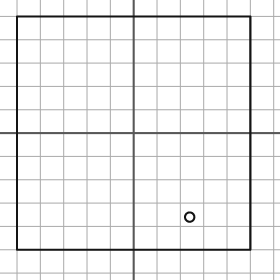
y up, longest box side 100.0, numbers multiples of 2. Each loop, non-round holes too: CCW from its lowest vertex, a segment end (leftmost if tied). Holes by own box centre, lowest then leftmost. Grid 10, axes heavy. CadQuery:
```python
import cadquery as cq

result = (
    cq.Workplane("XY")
    .moveTo(-50.0, -50.0)
    .lineTo(50.0, -50.0)
    .lineTo(50.0, 50.0)
    .lineTo(-50.0, 50.0)
    .close()
    .moveTo(24.0, -36.0)
    .circle(2.0)
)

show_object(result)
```